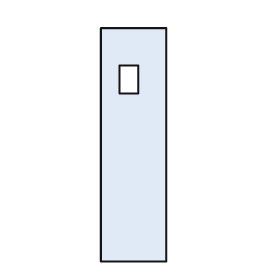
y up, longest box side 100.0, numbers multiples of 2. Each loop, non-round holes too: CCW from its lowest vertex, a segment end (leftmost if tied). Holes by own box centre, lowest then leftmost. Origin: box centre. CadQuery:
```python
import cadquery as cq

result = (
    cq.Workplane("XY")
    .moveTo(-14.0, -50.0)
    .lineTo(14.0, -50.0)
    .lineTo(14.0, 50.0)
    .lineTo(-14.0, 50.0)
    .close()
    .moveTo(-6.0, 22.0)
    .lineTo(2.0, 22.0)
    .lineTo(2.0, 34.0)
    .lineTo(-6.0, 34.0)
    .close()
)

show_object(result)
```